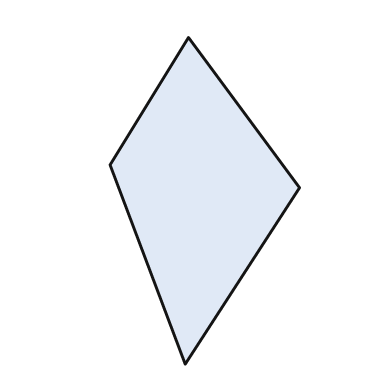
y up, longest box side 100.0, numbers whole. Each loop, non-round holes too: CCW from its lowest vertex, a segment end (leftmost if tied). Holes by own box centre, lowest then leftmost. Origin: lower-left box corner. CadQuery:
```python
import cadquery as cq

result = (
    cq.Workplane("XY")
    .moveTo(23.0, 0.0)
    .lineTo(58.0, 54.0)
    .lineTo(24.0, 100.0)
    .lineTo(0.0, 61.0)
    .close()
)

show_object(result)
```